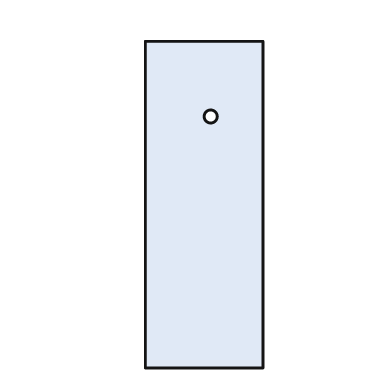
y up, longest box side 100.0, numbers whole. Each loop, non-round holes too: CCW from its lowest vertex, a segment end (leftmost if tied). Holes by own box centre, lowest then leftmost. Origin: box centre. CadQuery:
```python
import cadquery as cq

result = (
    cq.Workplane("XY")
    .moveTo(-18.0, -50.0)
    .lineTo(18.0, -50.0)
    .lineTo(18.0, 50.0)
    .lineTo(-18.0, 50.0)
    .close()
    .moveTo(2.0, 27.0)
    .circle(2.0)
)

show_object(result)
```